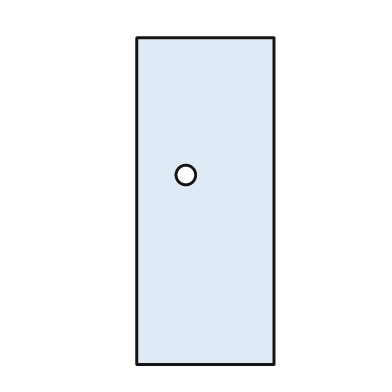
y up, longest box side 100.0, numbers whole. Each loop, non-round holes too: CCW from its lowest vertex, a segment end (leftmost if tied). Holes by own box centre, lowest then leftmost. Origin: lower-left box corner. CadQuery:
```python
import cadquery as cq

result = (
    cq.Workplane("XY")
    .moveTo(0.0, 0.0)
    .lineTo(42.0, 0.0)
    .lineTo(42.0, 100.0)
    .lineTo(0.0, 100.0)
    .close()
    .moveTo(15.0, 58.0)
    .circle(3.0)
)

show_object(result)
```